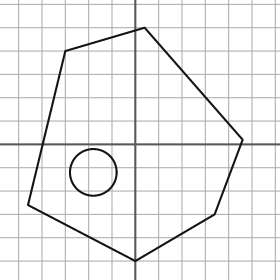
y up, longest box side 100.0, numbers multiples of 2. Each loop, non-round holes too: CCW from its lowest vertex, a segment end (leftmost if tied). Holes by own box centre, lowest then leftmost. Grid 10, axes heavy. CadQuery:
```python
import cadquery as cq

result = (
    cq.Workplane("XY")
    .moveTo(0.0, -50.0)
    .lineTo(34.0, -30.0)
    .lineTo(46.0, 2.0)
    .lineTo(4.0, 50.0)
    .lineTo(-30.0, 40.0)
    .lineTo(-46.0, -26.0)
    .close()
    .moveTo(-18.0, -12.0)
    .circle(10.0)
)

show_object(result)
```